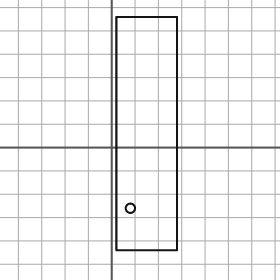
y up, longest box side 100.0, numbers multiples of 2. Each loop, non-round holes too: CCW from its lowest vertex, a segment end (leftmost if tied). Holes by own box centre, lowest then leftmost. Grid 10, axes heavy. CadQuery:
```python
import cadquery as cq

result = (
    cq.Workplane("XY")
    .moveTo(2.0, -44.0)
    .lineTo(28.0, -44.0)
    .lineTo(28.0, 56.0)
    .lineTo(2.0, 56.0)
    .close()
    .moveTo(8.0, -26.0)
    .circle(2.0)
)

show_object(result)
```